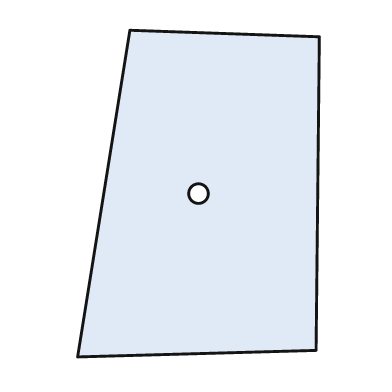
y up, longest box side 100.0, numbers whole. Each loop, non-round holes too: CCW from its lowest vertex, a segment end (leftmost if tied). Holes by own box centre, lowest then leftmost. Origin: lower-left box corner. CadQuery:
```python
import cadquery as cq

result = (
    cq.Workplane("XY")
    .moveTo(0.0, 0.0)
    .lineTo(73.0, 2.0)
    .lineTo(74.0, 98.0)
    .lineTo(16.0, 100.0)
    .close()
    .moveTo(37.0, 50.0)
    .circle(3.0)
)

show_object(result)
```